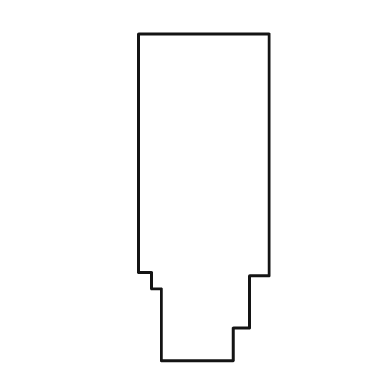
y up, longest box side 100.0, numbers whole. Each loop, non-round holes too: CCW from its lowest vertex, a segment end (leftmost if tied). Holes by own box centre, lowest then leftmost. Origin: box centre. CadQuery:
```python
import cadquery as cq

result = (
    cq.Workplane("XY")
    .moveTo(-13.0, -50.0)
    .lineTo(9.0, -50.0)
    .lineTo(9.0, -40.0)
    .lineTo(14.0, -40.0)
    .lineTo(14.0, -24.0)
    .lineTo(20.0, -24.0)
    .lineTo(20.0, 50.0)
    .lineTo(-20.0, 50.0)
    .lineTo(-20.0, -23.0)
    .lineTo(-16.0, -23.0)
    .lineTo(-16.0, -28.0)
    .lineTo(-13.0, -28.0)
    .close()
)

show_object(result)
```